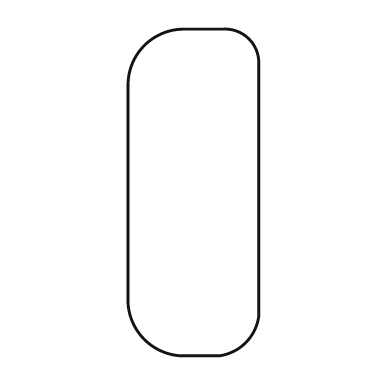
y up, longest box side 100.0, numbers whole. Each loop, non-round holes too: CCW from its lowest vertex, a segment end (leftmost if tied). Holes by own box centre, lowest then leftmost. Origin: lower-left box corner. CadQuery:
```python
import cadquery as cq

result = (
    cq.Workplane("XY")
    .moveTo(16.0, 0.0)
    .lineTo(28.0, 0.0)
    .threePointArc((36.0, 4.0), (40.0, 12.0))
    .lineTo(40.0, 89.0)
    .threePointArc((37.0, 97.0), (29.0, 100.0))
    .lineTo(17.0, 100.0)
    .threePointArc((5.0, 95.0), (0.0, 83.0))
    .lineTo(0.0, 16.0)
    .threePointArc((5.0, 5.0), (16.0, 0.0))
    .close()
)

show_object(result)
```